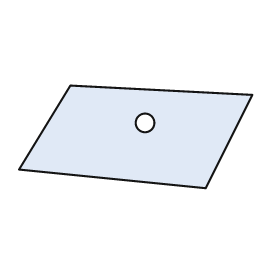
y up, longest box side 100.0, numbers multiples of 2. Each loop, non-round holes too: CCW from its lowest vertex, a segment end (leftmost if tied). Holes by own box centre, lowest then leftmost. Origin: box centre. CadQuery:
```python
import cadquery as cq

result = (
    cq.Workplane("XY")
    .moveTo(30.0, -22.0)
    .lineTo(50.0, 18.0)
    .lineTo(-28.0, 22.0)
    .lineTo(-50.0, -14.0)
    .close()
    .moveTo(4.0, 6.0)
    .circle(4.0)
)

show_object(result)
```